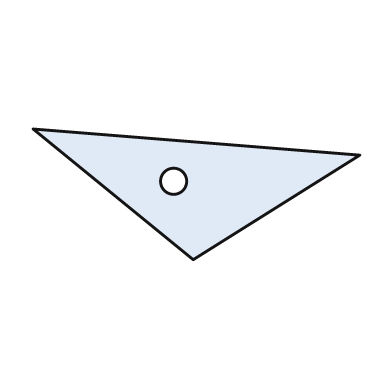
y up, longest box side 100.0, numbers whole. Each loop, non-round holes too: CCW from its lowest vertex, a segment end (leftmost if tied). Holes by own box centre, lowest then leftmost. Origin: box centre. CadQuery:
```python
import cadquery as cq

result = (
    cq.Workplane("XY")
    .moveTo(-1.0, -20.0)
    .lineTo(50.0, 12.0)
    .lineTo(-50.0, 20.0)
    .close()
    .moveTo(-7.0, 4.0)
    .circle(4.0)
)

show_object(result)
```